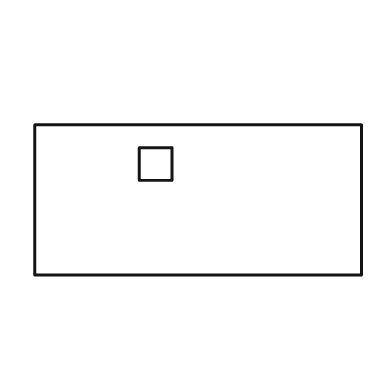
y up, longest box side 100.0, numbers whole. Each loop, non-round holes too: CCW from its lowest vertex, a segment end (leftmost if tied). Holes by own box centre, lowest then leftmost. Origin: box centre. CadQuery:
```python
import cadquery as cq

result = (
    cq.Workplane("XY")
    .moveTo(-50.0, -23.0)
    .lineTo(50.0, -23.0)
    .lineTo(50.0, 23.0)
    .lineTo(-50.0, 23.0)
    .close()
    .moveTo(-18.0, 6.0)
    .lineTo(-8.0, 6.0)
    .lineTo(-8.0, 16.0)
    .lineTo(-18.0, 16.0)
    .close()
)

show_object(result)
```